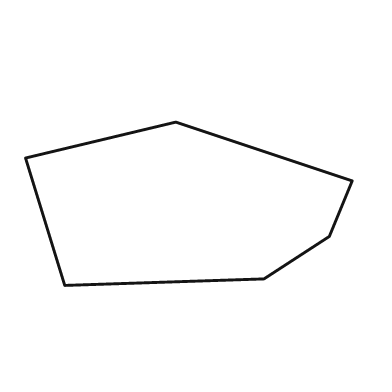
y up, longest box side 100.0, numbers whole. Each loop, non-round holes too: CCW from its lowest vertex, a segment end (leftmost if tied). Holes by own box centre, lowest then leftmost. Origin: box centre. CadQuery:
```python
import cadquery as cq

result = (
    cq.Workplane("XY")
    .moveTo(-38.0, -25.0)
    .lineTo(23.0, -23.0)
    .lineTo(43.0, -10.0)
    .lineTo(50.0, 7.0)
    .lineTo(-4.0, 25.0)
    .lineTo(-50.0, 14.0)
    .close()
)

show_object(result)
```